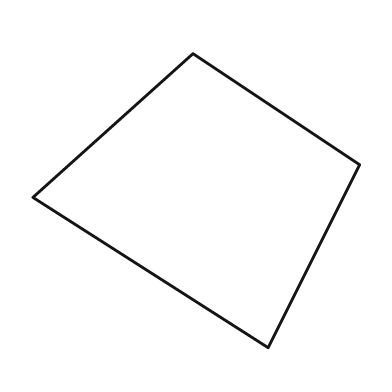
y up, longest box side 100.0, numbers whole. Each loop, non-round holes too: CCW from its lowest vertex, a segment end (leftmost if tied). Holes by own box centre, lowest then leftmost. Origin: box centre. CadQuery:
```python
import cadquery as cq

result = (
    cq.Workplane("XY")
    .moveTo(22.0, -45.0)
    .lineTo(50.0, 11.0)
    .lineTo(-1.0, 45.0)
    .lineTo(-50.0, 1.0)
    .close()
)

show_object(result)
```